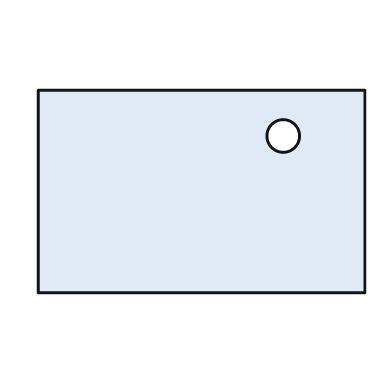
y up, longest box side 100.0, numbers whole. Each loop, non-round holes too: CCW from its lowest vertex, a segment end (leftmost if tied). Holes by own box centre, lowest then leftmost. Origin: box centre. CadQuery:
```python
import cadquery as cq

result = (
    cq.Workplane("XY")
    .moveTo(-50.0, -31.0)
    .lineTo(50.0, -31.0)
    .lineTo(50.0, 31.0)
    .lineTo(-50.0, 31.0)
    .close()
    .moveTo(25.0, 17.0)
    .circle(5.0)
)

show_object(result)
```